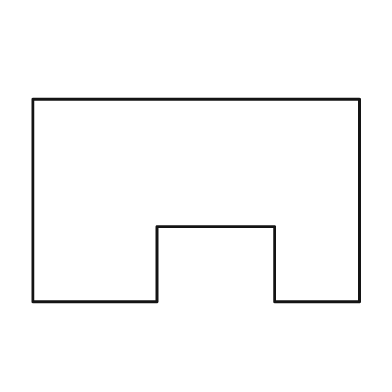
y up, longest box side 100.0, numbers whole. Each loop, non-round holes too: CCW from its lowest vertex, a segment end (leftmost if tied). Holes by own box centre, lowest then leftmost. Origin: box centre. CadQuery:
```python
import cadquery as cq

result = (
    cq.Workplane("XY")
    .moveTo(-50.0, -31.0)
    .lineTo(-12.0, -31.0)
    .lineTo(-12.0, -8.0)
    .lineTo(24.0, -8.0)
    .lineTo(24.0, -31.0)
    .lineTo(50.0, -31.0)
    .lineTo(50.0, 31.0)
    .lineTo(-50.0, 31.0)
    .close()
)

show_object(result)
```